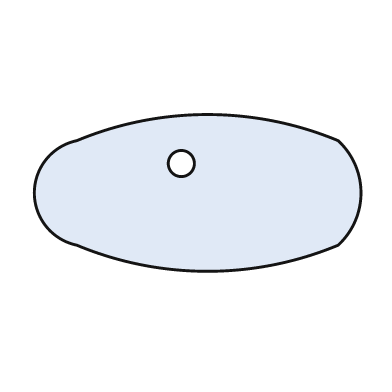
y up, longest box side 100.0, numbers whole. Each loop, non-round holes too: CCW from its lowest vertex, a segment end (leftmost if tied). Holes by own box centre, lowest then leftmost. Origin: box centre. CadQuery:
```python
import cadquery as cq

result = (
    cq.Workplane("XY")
    .moveTo(-37.0, -16.0)
    .threePointArc((3.0, -24.0), (43.0, -16.0))
    .threePointArc((50.0, 0.0), (43.0, 16.0))
    .threePointArc((3.0, 24.0), (-37.0, 16.0))
    .threePointArc((-50.0, 0.0), (-37.0, -16.0))
    .close()
    .moveTo(-5.0, 9.0)
    .circle(4.0)
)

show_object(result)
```